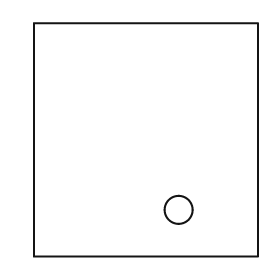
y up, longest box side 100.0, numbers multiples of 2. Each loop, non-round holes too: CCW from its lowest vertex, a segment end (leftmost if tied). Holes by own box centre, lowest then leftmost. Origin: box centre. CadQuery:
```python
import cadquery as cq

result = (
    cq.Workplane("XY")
    .moveTo(-48.0, -50.0)
    .lineTo(48.0, -50.0)
    .lineTo(48.0, 50.0)
    .lineTo(-48.0, 50.0)
    .close()
    .moveTo(14.0, -30.0)
    .circle(6.0)
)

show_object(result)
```